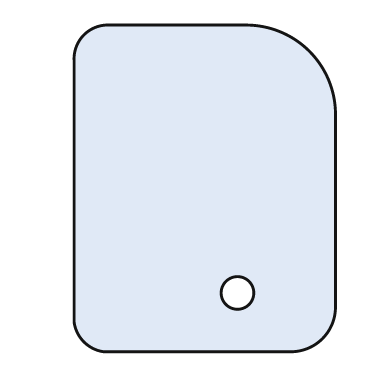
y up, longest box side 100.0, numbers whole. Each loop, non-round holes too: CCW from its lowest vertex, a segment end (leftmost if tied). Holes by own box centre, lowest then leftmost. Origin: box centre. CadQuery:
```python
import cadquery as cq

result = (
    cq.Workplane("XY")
    .moveTo(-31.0, -50.0)
    .lineTo(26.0, -50.0)
    .threePointArc((36.0, -46.0), (40.0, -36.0))
    .lineTo(40.0, 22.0)
    .threePointArc((32.0, 42.0), (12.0, 50.0))
    .lineTo(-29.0, 50.0)
    .threePointArc((-37.0, 47.0), (-40.0, 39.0))
    .lineTo(-40.0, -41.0)
    .threePointArc((-37.0, -47.0), (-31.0, -50.0))
    .close()
    .moveTo(10.0, -32.0)
    .circle(5.0)
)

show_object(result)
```